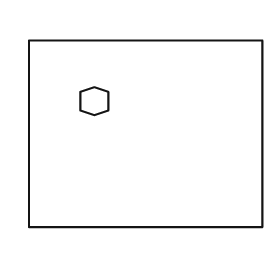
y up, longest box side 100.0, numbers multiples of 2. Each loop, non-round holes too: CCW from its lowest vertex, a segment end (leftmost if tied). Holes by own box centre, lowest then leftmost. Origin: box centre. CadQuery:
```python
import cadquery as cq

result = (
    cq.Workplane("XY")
    .moveTo(-50.0, -40.0)
    .lineTo(50.0, -40.0)
    .lineTo(50.0, 40.0)
    .lineTo(-50.0, 40.0)
    .close()
    .moveTo(-22.0, 8.0)
    .lineTo(-16.0, 10.0)
    .lineTo(-16.0, 18.0)
    .lineTo(-22.0, 20.0)
    .lineTo(-28.0, 18.0)
    .lineTo(-28.0, 10.0)
    .close()
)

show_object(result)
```